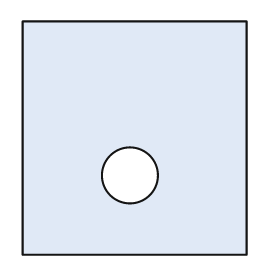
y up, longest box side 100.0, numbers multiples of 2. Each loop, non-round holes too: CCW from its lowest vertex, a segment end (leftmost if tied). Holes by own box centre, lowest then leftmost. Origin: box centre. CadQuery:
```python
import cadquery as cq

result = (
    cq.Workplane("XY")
    .moveTo(-48.0, -50.0)
    .lineTo(48.0, -50.0)
    .lineTo(48.0, 50.0)
    .lineTo(-48.0, 50.0)
    .close()
    .moveTo(-2.0, -16.0)
    .circle(12.0)
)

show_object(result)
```